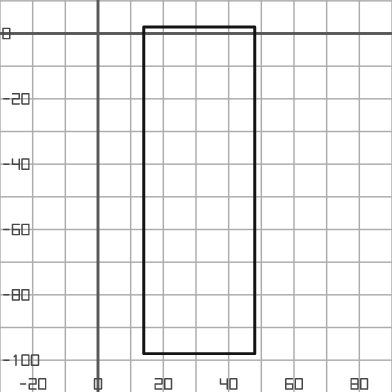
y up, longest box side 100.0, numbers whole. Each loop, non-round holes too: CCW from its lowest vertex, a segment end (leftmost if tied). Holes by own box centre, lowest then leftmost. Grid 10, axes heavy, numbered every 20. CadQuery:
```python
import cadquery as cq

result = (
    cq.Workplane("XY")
    .moveTo(14.0, -98.0)
    .lineTo(48.0, -98.0)
    .lineTo(48.0, 2.0)
    .lineTo(14.0, 2.0)
    .close()
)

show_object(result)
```